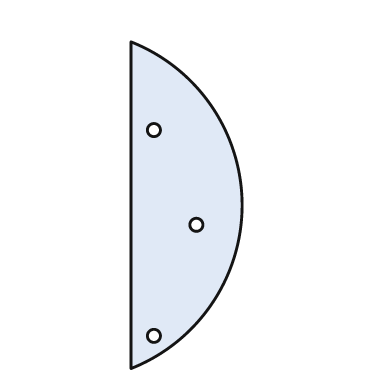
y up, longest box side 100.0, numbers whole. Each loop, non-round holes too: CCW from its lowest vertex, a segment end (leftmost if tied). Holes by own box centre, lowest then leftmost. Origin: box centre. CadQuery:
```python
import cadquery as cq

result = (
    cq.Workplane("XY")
    .moveTo(-17.0, -50.0)
    .threePointArc((17.0, 0.0), (-17.0, 50.0))
    .close()
    .moveTo(-10.0, -40.0)
    .circle(2.0)
    .moveTo(3.0, -6.0)
    .circle(2.0)
    .moveTo(-10.0, 23.0)
    .circle(2.0)
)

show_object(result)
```